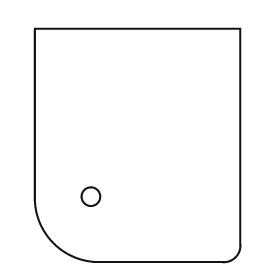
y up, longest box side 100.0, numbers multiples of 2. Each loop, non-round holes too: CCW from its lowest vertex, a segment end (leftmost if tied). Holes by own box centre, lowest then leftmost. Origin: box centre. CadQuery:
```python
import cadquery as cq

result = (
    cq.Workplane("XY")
    .moveTo(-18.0, -50.0)
    .lineTo(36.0, -50.0)
    .threePointArc((42.0, -48.0), (44.0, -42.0))
    .lineTo(44.0, 50.0)
    .lineTo(-44.0, 50.0)
    .lineTo(-44.0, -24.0)
    .threePointArc((-36.0, -42.0), (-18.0, -50.0))
    .close()
    .moveTo(-20.0, -22.0)
    .circle(4.0)
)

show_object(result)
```